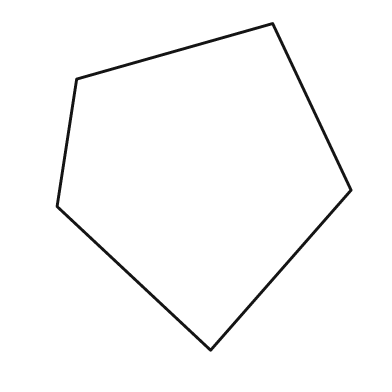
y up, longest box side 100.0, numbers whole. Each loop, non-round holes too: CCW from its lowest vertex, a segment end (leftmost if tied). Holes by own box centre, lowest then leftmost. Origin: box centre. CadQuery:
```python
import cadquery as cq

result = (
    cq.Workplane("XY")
    .moveTo(2.0, -50.0)
    .lineTo(45.0, -1.0)
    .lineTo(21.0, 50.0)
    .lineTo(-39.0, 33.0)
    .lineTo(-45.0, -6.0)
    .close()
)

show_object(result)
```